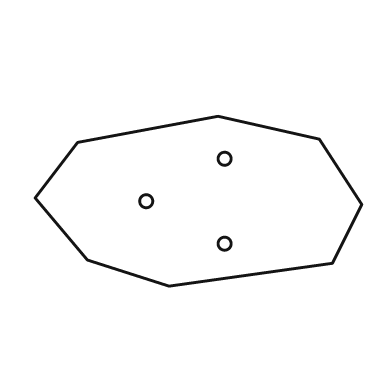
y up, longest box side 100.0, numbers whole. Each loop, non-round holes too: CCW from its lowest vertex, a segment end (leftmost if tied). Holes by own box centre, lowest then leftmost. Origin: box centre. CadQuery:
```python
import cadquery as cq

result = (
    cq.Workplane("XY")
    .moveTo(-9.0, -26.0)
    .lineTo(41.0, -19.0)
    .lineTo(50.0, -1.0)
    .lineTo(37.0, 19.0)
    .lineTo(6.0, 26.0)
    .lineTo(-37.0, 18.0)
    .lineTo(-50.0, 1.0)
    .lineTo(-34.0, -18.0)
    .close()
    .moveTo(8.0, -13.0)
    .circle(2.0)
    .moveTo(-16.0, 0.0)
    .circle(2.0)
    .moveTo(8.0, 13.0)
    .circle(2.0)
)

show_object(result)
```